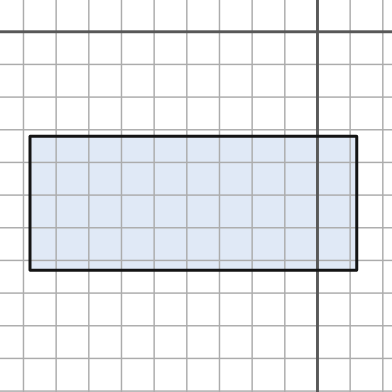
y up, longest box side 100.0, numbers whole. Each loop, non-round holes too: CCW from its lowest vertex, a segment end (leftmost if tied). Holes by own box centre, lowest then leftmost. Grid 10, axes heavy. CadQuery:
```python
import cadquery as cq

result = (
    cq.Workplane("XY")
    .moveTo(-88.0, -73.0)
    .lineTo(12.0, -73.0)
    .lineTo(12.0, -32.0)
    .lineTo(-88.0, -32.0)
    .close()
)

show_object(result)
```